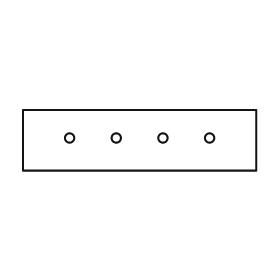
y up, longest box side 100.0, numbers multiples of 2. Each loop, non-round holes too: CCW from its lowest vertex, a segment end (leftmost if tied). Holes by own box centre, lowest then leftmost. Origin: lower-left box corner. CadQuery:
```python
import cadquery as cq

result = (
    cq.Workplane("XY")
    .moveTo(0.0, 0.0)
    .lineTo(100.0, 0.0)
    .lineTo(100.0, 26.0)
    .lineTo(0.0, 26.0)
    .close()
    .moveTo(20.0, 14.0)
    .circle(2.0)
    .moveTo(40.0, 14.0)
    .circle(2.0)
    .moveTo(60.0, 14.0)
    .circle(2.0)
    .moveTo(80.0, 14.0)
    .circle(2.0)
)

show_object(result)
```